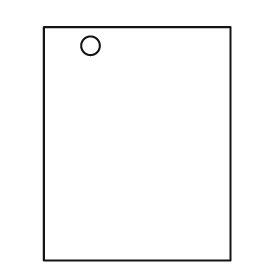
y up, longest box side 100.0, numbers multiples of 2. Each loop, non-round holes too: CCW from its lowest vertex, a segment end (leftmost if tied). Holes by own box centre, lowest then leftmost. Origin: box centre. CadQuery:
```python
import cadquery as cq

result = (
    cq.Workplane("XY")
    .moveTo(-40.0, -50.0)
    .lineTo(40.0, -50.0)
    .lineTo(40.0, 50.0)
    .lineTo(-40.0, 50.0)
    .close()
    .moveTo(-20.0, 42.0)
    .circle(4.0)
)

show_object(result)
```